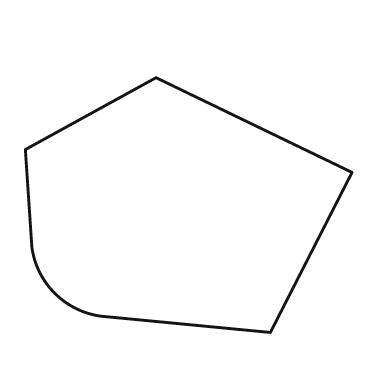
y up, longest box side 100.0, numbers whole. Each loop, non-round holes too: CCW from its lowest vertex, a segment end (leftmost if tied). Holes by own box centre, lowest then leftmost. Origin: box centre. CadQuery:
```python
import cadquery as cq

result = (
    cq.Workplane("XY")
    .moveTo(25.0, -39.0)
    .lineTo(50.0, 10.0)
    .lineTo(-10.0, 39.0)
    .lineTo(-50.0, 17.0)
    .lineTo(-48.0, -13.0)
    .threePointArc((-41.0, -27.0), (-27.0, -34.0))
    .close()
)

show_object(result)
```